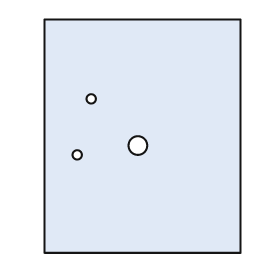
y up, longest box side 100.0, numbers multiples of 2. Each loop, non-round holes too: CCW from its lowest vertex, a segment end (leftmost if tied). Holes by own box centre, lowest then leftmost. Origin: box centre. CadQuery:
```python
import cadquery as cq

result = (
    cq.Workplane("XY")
    .moveTo(-42.0, -50.0)
    .lineTo(42.0, -50.0)
    .lineTo(42.0, 50.0)
    .lineTo(-42.0, 50.0)
    .close()
    .moveTo(-28.0, -8.0)
    .circle(2.0)
    .moveTo(-2.0, -4.0)
    .circle(4.0)
    .moveTo(-22.0, 16.0)
    .circle(2.0)
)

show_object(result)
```